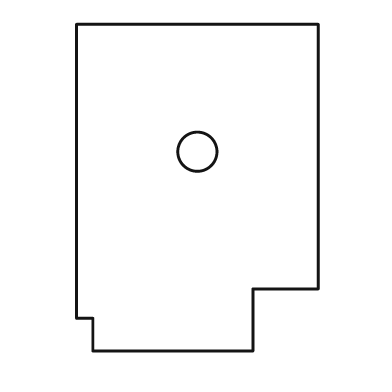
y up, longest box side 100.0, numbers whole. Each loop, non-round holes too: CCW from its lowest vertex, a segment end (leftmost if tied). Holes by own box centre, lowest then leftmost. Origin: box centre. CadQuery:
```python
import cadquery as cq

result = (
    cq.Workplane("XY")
    .moveTo(-32.0, -50.0)
    .lineTo(17.0, -50.0)
    .lineTo(17.0, -31.0)
    .lineTo(37.0, -31.0)
    .lineTo(37.0, 50.0)
    .lineTo(-37.0, 50.0)
    .lineTo(-37.0, -40.0)
    .lineTo(-32.0, -40.0)
    .close()
    .moveTo(0.0, 11.0)
    .circle(6.0)
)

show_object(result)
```